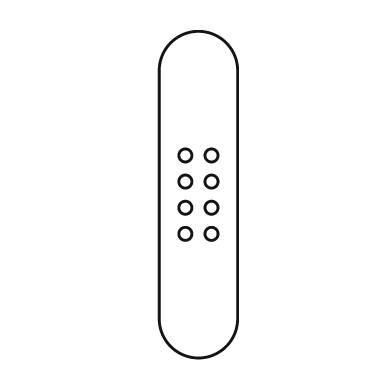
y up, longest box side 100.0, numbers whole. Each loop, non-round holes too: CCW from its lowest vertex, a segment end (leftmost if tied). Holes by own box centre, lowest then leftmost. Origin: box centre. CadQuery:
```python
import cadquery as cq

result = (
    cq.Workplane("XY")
    .moveTo(-12.0, -38.0)
    .threePointArc((0.0, -50.0), (12.0, -38.0))
    .lineTo(12.0, 38.0)
    .threePointArc((0.0, 50.0), (-12.0, 38.0))
    .close()
    .moveTo(-4.0, -12.0)
    .circle(2.0)
    .moveTo(4.0, -12.0)
    .circle(2.0)
    .moveTo(-4.0, -4.0)
    .circle(2.0)
    .moveTo(4.0, -4.0)
    .circle(2.0)
    .moveTo(-4.0, 4.0)
    .circle(2.0)
    .moveTo(4.0, 4.0)
    .circle(2.0)
    .moveTo(-4.0, 12.0)
    .circle(2.0)
    .moveTo(4.0, 12.0)
    .circle(2.0)
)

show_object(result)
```